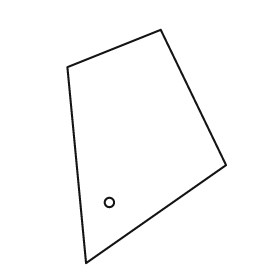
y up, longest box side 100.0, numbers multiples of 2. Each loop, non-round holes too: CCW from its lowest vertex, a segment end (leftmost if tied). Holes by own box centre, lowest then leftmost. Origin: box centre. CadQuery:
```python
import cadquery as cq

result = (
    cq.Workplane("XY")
    .moveTo(-26.0, -50.0)
    .lineTo(34.0, -8.0)
    .lineTo(6.0, 50.0)
    .lineTo(-34.0, 34.0)
    .close()
    .moveTo(-16.0, -24.0)
    .circle(2.0)
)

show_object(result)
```